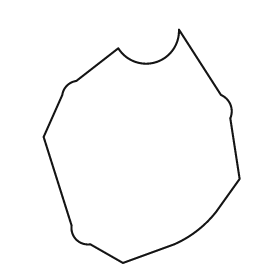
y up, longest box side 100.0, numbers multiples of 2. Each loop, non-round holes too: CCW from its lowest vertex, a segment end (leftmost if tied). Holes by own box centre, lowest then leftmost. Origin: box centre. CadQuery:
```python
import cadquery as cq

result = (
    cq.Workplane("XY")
    .moveTo(-8.0, -50.0)
    .lineTo(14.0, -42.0)
    .threePointArc((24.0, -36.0), (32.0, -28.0))
    .lineTo(42.0, -14.0)
    .lineTo(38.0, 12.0)
    .threePointArc((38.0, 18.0), (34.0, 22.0))
    .lineTo(16.0, 50.0)
    .threePointArc((6.0, 36.0), (-10.0, 42.0))
    .lineTo(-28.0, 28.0)
    .threePointArc((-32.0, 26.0), (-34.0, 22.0))
    .lineTo(-42.0, 4.0)
    .lineTo(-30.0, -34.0)
    .threePointArc((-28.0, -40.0), (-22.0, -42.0))
    .close()
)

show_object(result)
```